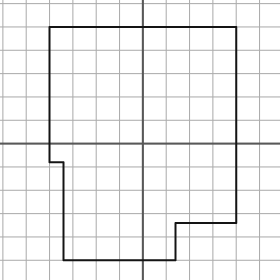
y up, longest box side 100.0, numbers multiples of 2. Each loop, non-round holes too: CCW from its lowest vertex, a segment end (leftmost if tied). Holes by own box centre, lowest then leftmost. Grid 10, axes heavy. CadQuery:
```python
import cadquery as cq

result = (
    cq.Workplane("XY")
    .moveTo(-34.0, -50.0)
    .lineTo(14.0, -50.0)
    .lineTo(14.0, -34.0)
    .lineTo(40.0, -34.0)
    .lineTo(40.0, 50.0)
    .lineTo(-40.0, 50.0)
    .lineTo(-40.0, -8.0)
    .lineTo(-34.0, -8.0)
    .close()
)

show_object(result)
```